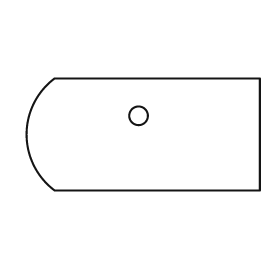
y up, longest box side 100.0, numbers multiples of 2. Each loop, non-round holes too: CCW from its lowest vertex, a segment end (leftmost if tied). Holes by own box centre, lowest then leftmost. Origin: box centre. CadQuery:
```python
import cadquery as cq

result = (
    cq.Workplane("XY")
    .moveTo(-38.0, -24.0)
    .lineTo(50.0, -24.0)
    .lineTo(50.0, 24.0)
    .lineTo(-38.0, 24.0)
    .threePointArc((-50.0, 0.0), (-38.0, -24.0))
    .close()
    .moveTo(-2.0, 8.0)
    .circle(4.0)
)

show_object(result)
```